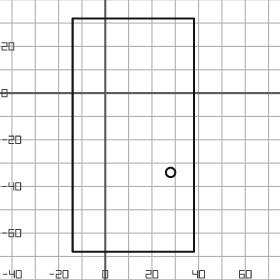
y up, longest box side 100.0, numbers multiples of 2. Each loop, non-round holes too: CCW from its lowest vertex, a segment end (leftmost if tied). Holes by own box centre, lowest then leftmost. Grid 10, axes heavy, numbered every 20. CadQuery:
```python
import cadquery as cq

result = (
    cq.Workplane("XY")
    .moveTo(-14.0, -68.0)
    .lineTo(38.0, -68.0)
    .lineTo(38.0, 32.0)
    .lineTo(-14.0, 32.0)
    .close()
    .moveTo(28.0, -34.0)
    .circle(2.0)
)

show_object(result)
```